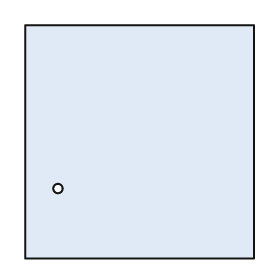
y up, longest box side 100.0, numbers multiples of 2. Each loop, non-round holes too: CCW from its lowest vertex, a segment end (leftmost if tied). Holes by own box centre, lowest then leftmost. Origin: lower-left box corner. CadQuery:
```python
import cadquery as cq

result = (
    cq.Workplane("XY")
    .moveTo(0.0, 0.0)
    .lineTo(98.0, 0.0)
    .lineTo(98.0, 100.0)
    .lineTo(0.0, 100.0)
    .close()
    .moveTo(14.0, 30.0)
    .circle(2.0)
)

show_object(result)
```